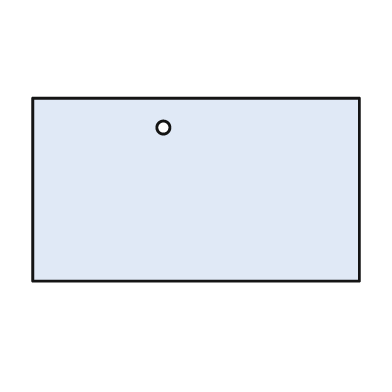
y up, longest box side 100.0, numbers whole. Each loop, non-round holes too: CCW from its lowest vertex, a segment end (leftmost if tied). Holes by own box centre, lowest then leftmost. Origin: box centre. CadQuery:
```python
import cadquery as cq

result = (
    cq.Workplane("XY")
    .moveTo(-50.0, -28.0)
    .lineTo(50.0, -28.0)
    .lineTo(50.0, 28.0)
    .lineTo(-50.0, 28.0)
    .close()
    .moveTo(-10.0, 19.0)
    .circle(2.0)
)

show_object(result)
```